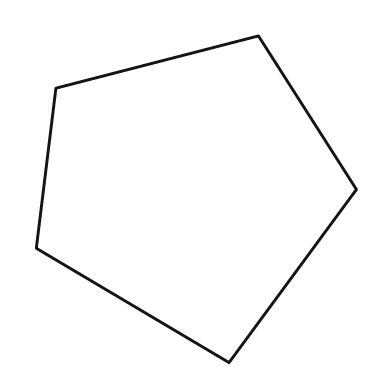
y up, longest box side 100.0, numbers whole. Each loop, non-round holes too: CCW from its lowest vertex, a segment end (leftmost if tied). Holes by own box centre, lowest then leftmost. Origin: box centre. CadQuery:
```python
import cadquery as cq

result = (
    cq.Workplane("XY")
    .moveTo(10.0, -50.0)
    .lineTo(49.0, 3.0)
    .lineTo(19.0, 50.0)
    .lineTo(-43.0, 34.0)
    .lineTo(-49.0, -15.0)
    .close()
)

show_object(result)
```